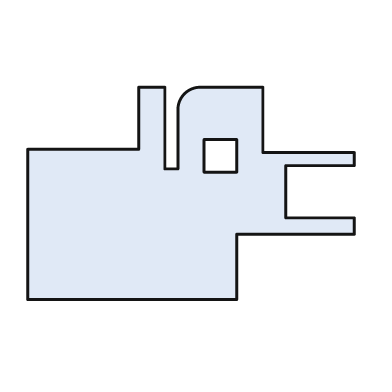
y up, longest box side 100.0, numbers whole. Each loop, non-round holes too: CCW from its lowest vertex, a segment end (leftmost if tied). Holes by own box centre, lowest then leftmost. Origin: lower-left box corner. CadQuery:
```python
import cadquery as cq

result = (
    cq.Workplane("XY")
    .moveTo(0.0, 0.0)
    .lineTo(64.0, 0.0)
    .lineTo(64.0, 20.0)
    .lineTo(100.0, 20.0)
    .lineTo(100.0, 25.0)
    .lineTo(79.0, 25.0)
    .lineTo(79.0, 41.0)
    .lineTo(100.0, 41.0)
    .lineTo(100.0, 45.0)
    .lineTo(72.0, 45.0)
    .lineTo(72.0, 65.0)
    .lineTo(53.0, 65.0)
    .threePointArc((48.0, 63.0), (46.0, 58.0))
    .lineTo(46.0, 40.0)
    .lineTo(42.0, 40.0)
    .lineTo(42.0, 65.0)
    .lineTo(34.0, 65.0)
    .lineTo(34.0, 46.0)
    .lineTo(0.0, 46.0)
    .close()
    .moveTo(54.0, 39.0)
    .lineTo(64.0, 39.0)
    .lineTo(64.0, 49.0)
    .lineTo(54.0, 49.0)
    .close()
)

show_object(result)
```